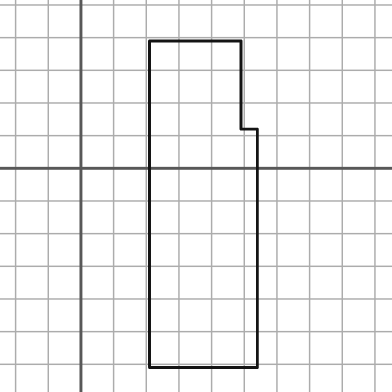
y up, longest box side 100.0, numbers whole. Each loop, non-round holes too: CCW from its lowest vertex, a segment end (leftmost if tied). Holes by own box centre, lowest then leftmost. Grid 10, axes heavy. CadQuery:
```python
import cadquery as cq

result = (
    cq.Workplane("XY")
    .moveTo(21.0, -61.0)
    .lineTo(54.0, -61.0)
    .lineTo(54.0, 12.0)
    .lineTo(49.0, 12.0)
    .lineTo(49.0, 39.0)
    .lineTo(21.0, 39.0)
    .close()
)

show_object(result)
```